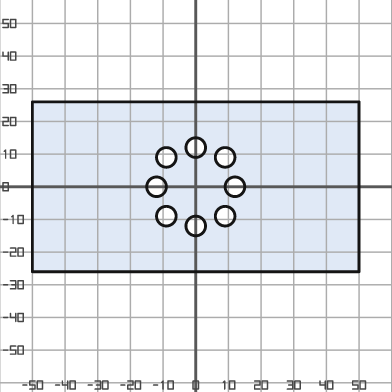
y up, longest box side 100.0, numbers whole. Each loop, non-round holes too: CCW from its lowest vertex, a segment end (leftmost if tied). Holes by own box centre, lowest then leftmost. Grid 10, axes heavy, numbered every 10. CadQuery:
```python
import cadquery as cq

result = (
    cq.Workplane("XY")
    .moveTo(-50.0, -26.0)
    .lineTo(50.0, -26.0)
    .lineTo(50.0, 26.0)
    .lineTo(-50.0, 26.0)
    .close()
    .moveTo(0.0, -12.0)
    .circle(3.0)
    .moveTo(-9.0, -9.0)
    .circle(3.0)
    .moveTo(9.0, -9.0)
    .circle(3.0)
    .moveTo(-12.0, 0.0)
    .circle(3.0)
    .moveTo(12.0, 0.0)
    .circle(3.0)
    .moveTo(-9.0, 9.0)
    .circle(3.0)
    .moveTo(9.0, 9.0)
    .circle(3.0)
    .moveTo(0.0, 12.0)
    .circle(3.0)
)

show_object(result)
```